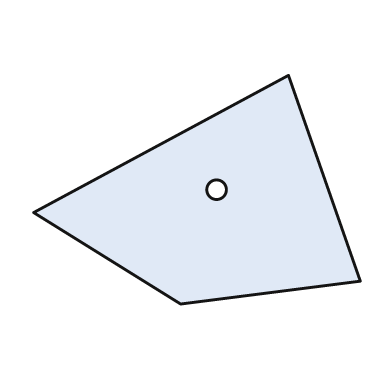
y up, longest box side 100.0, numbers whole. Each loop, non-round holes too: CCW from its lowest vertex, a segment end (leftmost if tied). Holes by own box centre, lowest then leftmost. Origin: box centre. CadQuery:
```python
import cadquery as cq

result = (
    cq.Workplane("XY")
    .moveTo(-5.0, -35.0)
    .lineTo(50.0, -28.0)
    .lineTo(28.0, 35.0)
    .lineTo(-50.0, -7.0)
    .close()
    .moveTo(6.0, 0.0)
    .circle(3.0)
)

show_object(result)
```